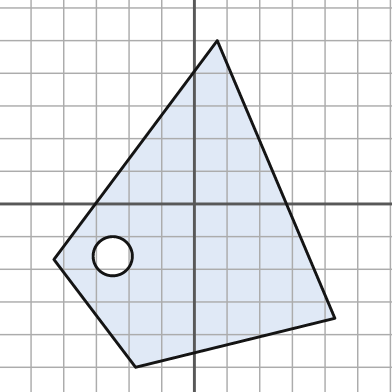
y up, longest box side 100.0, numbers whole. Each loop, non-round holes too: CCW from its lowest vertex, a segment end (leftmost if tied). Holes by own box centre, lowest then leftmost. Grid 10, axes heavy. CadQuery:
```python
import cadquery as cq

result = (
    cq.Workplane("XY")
    .moveTo(-18.0, -50.0)
    .lineTo(43.0, -35.0)
    .lineTo(7.0, 50.0)
    .lineTo(-43.0, -17.0)
    .close()
    .moveTo(-25.0, -16.0)
    .circle(6.0)
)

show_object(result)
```